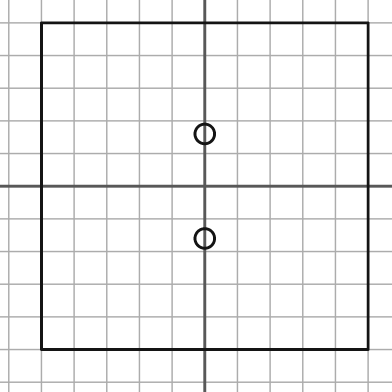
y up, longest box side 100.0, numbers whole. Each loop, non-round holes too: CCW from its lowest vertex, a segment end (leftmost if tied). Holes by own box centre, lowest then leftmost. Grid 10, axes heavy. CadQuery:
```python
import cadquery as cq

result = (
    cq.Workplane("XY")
    .moveTo(-50.0, -50.0)
    .lineTo(50.0, -50.0)
    .lineTo(50.0, 50.0)
    .lineTo(-50.0, 50.0)
    .close()
    .moveTo(0.0, -16.0)
    .circle(3.0)
    .moveTo(0.0, 16.0)
    .circle(3.0)
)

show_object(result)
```